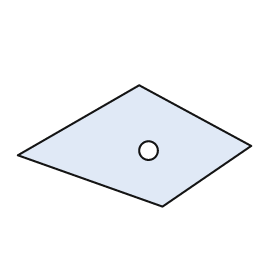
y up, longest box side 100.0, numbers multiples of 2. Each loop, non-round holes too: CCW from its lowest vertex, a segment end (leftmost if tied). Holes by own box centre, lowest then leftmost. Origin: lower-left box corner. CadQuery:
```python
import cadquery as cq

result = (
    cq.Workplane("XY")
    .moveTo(62.0, 0.0)
    .lineTo(100.0, 26.0)
    .lineTo(52.0, 52.0)
    .lineTo(0.0, 22.0)
    .close()
    .moveTo(56.0, 24.0)
    .circle(4.0)
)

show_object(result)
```